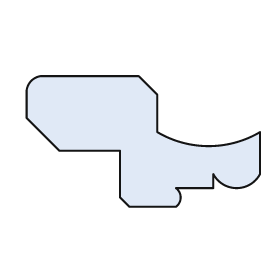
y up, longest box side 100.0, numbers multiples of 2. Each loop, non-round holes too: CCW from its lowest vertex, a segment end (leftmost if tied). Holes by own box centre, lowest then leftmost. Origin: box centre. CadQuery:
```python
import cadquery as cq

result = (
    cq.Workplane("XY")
    .moveTo(-6.0, -28.0)
    .lineTo(14.0, -28.0)
    .threePointArc((16.0, -24.0), (14.0, -20.0))
    .lineTo(30.0, -20.0)
    .lineTo(30.0, -14.0)
    .threePointArc((40.0, -20.0), (50.0, -14.0))
    .lineTo(50.0, 4.0)
    .threePointArc((28.0, -2.0), (6.0, 4.0))
    .lineTo(6.0, 20.0)
    .lineTo(-2.0, 28.0)
    .lineTo(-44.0, 28.0)
    .threePointArc((-48.0, 26.0), (-50.0, 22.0))
    .lineTo(-50.0, 10.0)
    .lineTo(-36.0, -4.0)
    .lineTo(-10.0, -4.0)
    .lineTo(-10.0, -24.0)
    .close()
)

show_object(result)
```